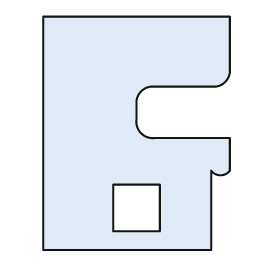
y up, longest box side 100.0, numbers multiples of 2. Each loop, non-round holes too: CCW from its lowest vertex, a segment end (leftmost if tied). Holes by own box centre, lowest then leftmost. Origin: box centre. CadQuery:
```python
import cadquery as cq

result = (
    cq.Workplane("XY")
    .moveTo(-40.0, -50.0)
    .lineTo(32.0, -50.0)
    .lineTo(32.0, -16.0)
    .threePointArc((36.0, -18.0), (40.0, -16.0))
    .lineTo(40.0, -2.0)
    .lineTo(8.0, -2.0)
    .threePointArc((2.0, 0.0), (0.0, 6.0))
    .lineTo(0.0, 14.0)
    .threePointArc((2.0, 18.0), (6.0, 20.0))
    .lineTo(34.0, 20.0)
    .threePointArc((38.0, 22.0), (40.0, 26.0))
    .lineTo(40.0, 50.0)
    .lineTo(-40.0, 50.0)
    .close()
    .moveTo(-10.0, -42.0)
    .lineTo(10.0, -42.0)
    .lineTo(10.0, -22.0)
    .lineTo(-10.0, -22.0)
    .close()
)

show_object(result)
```